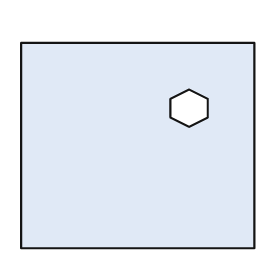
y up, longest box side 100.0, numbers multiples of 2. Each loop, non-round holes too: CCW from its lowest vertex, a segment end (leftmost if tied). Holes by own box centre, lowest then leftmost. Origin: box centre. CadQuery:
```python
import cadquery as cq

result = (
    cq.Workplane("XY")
    .moveTo(-50.0, -44.0)
    .lineTo(50.0, -44.0)
    .lineTo(50.0, 44.0)
    .lineTo(-50.0, 44.0)
    .close()
    .moveTo(22.0, 8.0)
    .lineTo(30.0, 12.0)
    .lineTo(30.0, 20.0)
    .lineTo(22.0, 24.0)
    .lineTo(14.0, 20.0)
    .lineTo(14.0, 12.0)
    .close()
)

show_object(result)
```